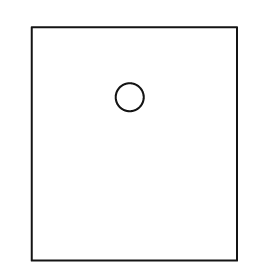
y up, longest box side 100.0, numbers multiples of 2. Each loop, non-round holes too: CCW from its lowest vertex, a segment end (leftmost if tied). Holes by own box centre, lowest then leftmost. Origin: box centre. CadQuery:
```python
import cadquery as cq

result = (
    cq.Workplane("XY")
    .moveTo(-44.0, -50.0)
    .lineTo(44.0, -50.0)
    .lineTo(44.0, 50.0)
    .lineTo(-44.0, 50.0)
    .close()
    .moveTo(-2.0, 20.0)
    .circle(6.0)
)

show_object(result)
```